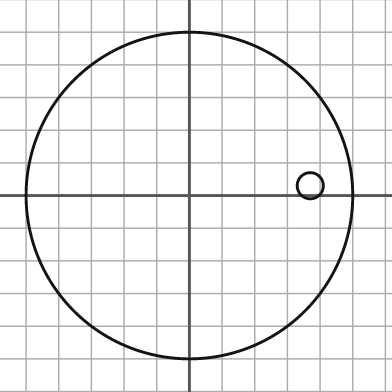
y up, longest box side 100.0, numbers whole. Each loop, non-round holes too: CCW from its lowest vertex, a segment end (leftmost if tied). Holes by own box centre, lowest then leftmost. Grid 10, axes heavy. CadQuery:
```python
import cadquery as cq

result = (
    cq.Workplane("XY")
    .moveTo(0.0, 0.0)
    .circle(50.0)
    .moveTo(37.0, 3.0)
    .circle(4.0)
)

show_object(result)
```